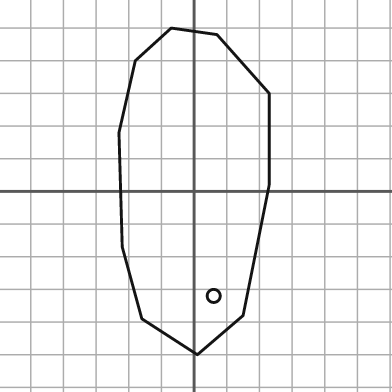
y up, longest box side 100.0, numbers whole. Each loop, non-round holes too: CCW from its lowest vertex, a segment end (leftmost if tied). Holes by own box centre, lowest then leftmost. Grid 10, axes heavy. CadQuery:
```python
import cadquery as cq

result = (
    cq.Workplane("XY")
    .moveTo(1.0, -50.0)
    .lineTo(15.0, -38.0)
    .lineTo(23.0, 2.0)
    .lineTo(23.0, 30.0)
    .lineTo(7.0, 48.0)
    .lineTo(-7.0, 50.0)
    .lineTo(-18.0, 40.0)
    .lineTo(-23.0, 18.0)
    .lineTo(-22.0, -17.0)
    .lineTo(-16.0, -39.0)
    .close()
    .moveTo(6.0, -32.0)
    .circle(2.0)
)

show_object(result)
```